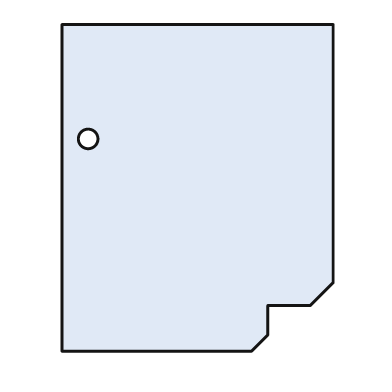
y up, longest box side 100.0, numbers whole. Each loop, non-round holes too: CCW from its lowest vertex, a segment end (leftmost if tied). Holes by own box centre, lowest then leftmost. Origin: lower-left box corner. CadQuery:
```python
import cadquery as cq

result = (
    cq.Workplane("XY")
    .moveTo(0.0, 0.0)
    .lineTo(58.0, 0.0)
    .lineTo(63.0, 5.0)
    .lineTo(63.0, 14.0)
    .lineTo(76.0, 14.0)
    .lineTo(83.0, 21.0)
    .lineTo(83.0, 100.0)
    .lineTo(0.0, 100.0)
    .close()
    .moveTo(8.0, 65.0)
    .circle(3.0)
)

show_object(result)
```